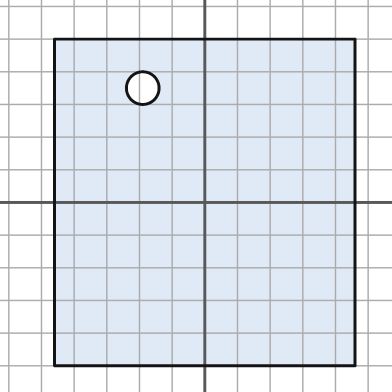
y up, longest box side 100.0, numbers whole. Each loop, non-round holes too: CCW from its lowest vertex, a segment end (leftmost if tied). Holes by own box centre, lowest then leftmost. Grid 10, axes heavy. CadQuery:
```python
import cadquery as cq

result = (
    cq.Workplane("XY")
    .moveTo(-46.0, -50.0)
    .lineTo(46.0, -50.0)
    .lineTo(46.0, 50.0)
    .lineTo(-46.0, 50.0)
    .close()
    .moveTo(-19.0, 35.0)
    .circle(5.0)
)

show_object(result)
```